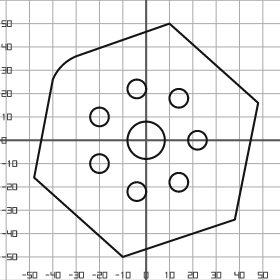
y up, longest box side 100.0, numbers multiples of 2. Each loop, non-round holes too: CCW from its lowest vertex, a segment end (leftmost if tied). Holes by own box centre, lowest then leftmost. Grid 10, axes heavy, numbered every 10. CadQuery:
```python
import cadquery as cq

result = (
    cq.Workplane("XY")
    .moveTo(-10.0, -50.0)
    .lineTo(38.0, -34.0)
    .lineTo(48.0, 16.0)
    .lineTo(10.0, 50.0)
    .lineTo(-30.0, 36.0)
    .threePointArc((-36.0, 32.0), (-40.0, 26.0))
    .lineTo(-48.0, -16.0)
    .close()
    .moveTo(-4.0, -22.0)
    .circle(4.0)
    .moveTo(14.0, -18.0)
    .circle(4.0)
    .moveTo(-20.0, -10.0)
    .circle(4.0)
    .moveTo(0.0, 0.0)
    .circle(8.0)
    .moveTo(22.0, 0.0)
    .circle(4.0)
    .moveTo(-20.0, 10.0)
    .circle(4.0)
    .moveTo(14.0, 18.0)
    .circle(4.0)
    .moveTo(-4.0, 22.0)
    .circle(4.0)
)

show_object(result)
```